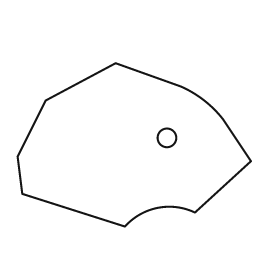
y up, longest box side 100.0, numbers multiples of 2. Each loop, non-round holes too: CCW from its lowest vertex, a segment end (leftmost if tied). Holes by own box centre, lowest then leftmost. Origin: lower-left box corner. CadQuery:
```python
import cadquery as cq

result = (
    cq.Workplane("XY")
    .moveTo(46.0, 0.0)
    .threePointArc((60.0, 8.0), (76.0, 6.0))
    .lineTo(100.0, 28.0)
    .lineTo(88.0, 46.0)
    .threePointArc((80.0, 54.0), (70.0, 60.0))
    .lineTo(42.0, 70.0)
    .lineTo(12.0, 54.0)
    .lineTo(0.0, 30.0)
    .lineTo(2.0, 14.0)
    .close()
    .moveTo(64.0, 38.0)
    .circle(4.0)
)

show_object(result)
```